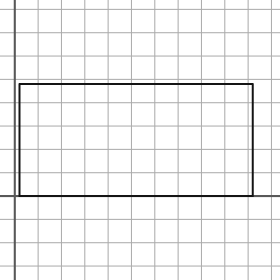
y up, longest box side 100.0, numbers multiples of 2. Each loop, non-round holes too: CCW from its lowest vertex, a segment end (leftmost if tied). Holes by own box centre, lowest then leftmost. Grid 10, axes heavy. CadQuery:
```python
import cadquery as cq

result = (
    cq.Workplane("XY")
    .moveTo(2.0, 0.0)
    .lineTo(102.0, 0.0)
    .lineTo(102.0, 48.0)
    .lineTo(2.0, 48.0)
    .close()
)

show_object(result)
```